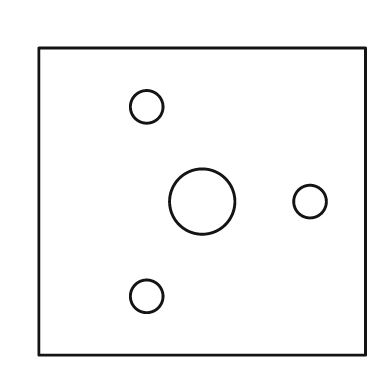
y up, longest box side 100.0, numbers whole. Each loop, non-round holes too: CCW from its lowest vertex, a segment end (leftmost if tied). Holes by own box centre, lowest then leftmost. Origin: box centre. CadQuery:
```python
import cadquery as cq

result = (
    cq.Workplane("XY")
    .moveTo(-50.0, -47.0)
    .lineTo(50.0, -47.0)
    .lineTo(50.0, 47.0)
    .lineTo(-50.0, 47.0)
    .close()
    .moveTo(-17.0, -29.0)
    .circle(5.0)
    .moveTo(0.0, 0.0)
    .circle(10.0)
    .moveTo(33.0, 0.0)
    .circle(5.0)
    .moveTo(-17.0, 29.0)
    .circle(5.0)
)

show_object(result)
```